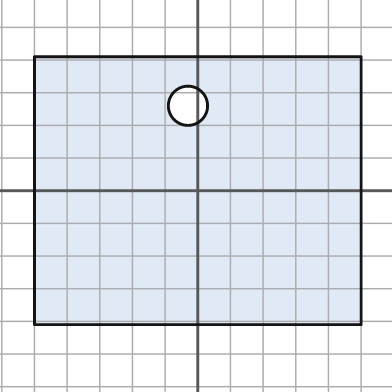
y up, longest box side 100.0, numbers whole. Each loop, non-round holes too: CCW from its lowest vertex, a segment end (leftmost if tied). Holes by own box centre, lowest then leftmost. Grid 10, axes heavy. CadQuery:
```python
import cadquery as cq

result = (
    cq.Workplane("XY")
    .moveTo(-50.0, -41.0)
    .lineTo(50.0, -41.0)
    .lineTo(50.0, 41.0)
    .lineTo(-50.0, 41.0)
    .close()
    .moveTo(-3.0, 26.0)
    .circle(6.0)
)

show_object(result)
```